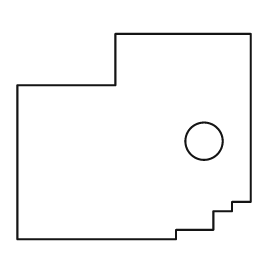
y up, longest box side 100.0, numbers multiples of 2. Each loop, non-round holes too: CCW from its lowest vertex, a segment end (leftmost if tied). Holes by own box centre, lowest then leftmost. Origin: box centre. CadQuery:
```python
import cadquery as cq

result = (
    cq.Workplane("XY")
    .moveTo(-50.0, -44.0)
    .lineTo(18.0, -44.0)
    .lineTo(18.0, -40.0)
    .lineTo(34.0, -40.0)
    .lineTo(34.0, -32.0)
    .lineTo(42.0, -32.0)
    .lineTo(42.0, -28.0)
    .lineTo(50.0, -28.0)
    .lineTo(50.0, 44.0)
    .lineTo(-8.0, 44.0)
    .lineTo(-8.0, 22.0)
    .lineTo(-50.0, 22.0)
    .close()
    .moveTo(30.0, -2.0)
    .circle(8.0)
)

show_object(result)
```